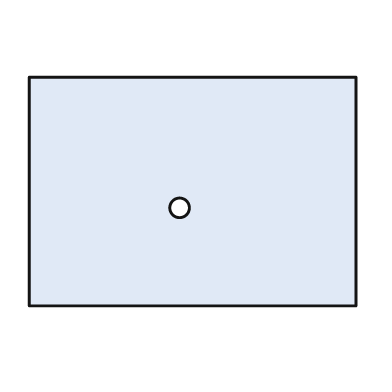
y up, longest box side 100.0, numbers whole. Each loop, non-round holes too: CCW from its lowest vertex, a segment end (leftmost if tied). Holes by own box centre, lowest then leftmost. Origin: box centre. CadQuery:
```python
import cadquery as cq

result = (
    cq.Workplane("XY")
    .moveTo(-50.0, -35.0)
    .lineTo(50.0, -35.0)
    .lineTo(50.0, 35.0)
    .lineTo(-50.0, 35.0)
    .close()
    .moveTo(-4.0, -5.0)
    .circle(3.0)
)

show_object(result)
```